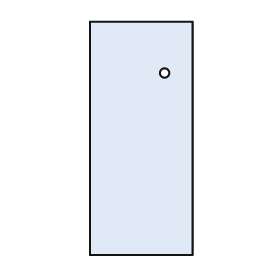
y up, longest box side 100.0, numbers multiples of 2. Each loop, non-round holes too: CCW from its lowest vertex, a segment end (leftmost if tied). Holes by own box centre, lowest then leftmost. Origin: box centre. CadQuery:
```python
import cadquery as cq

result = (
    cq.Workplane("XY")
    .moveTo(-22.0, -50.0)
    .lineTo(22.0, -50.0)
    .lineTo(22.0, 50.0)
    .lineTo(-22.0, 50.0)
    .close()
    .moveTo(10.0, 28.0)
    .circle(2.0)
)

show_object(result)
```